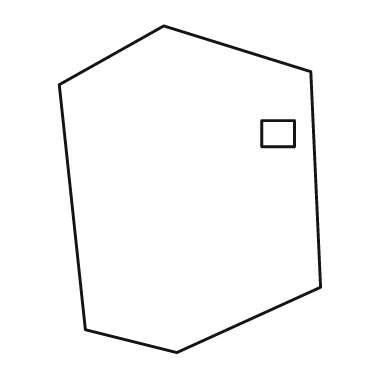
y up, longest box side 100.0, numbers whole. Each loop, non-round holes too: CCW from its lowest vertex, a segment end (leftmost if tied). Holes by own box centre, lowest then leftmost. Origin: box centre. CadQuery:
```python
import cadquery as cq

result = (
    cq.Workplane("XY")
    .moveTo(-4.0, -50.0)
    .lineTo(40.0, -30.0)
    .lineTo(37.0, 36.0)
    .lineTo(-8.0, 50.0)
    .lineTo(-40.0, 32.0)
    .lineTo(-32.0, -43.0)
    .close()
    .moveTo(22.0, 13.0)
    .lineTo(32.0, 13.0)
    .lineTo(32.0, 21.0)
    .lineTo(22.0, 21.0)
    .close()
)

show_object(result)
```